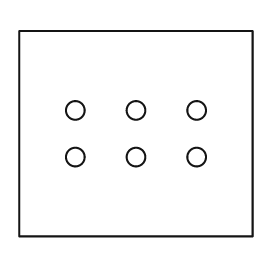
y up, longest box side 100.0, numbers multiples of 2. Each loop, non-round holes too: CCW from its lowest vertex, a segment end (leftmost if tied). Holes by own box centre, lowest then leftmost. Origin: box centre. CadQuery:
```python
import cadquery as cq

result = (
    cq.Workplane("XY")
    .moveTo(-50.0, -44.0)
    .lineTo(50.0, -44.0)
    .lineTo(50.0, 44.0)
    .lineTo(-50.0, 44.0)
    .close()
    .moveTo(-26.0, -10.0)
    .circle(4.0)
    .moveTo(0.0, -10.0)
    .circle(4.0)
    .moveTo(26.0, -10.0)
    .circle(4.0)
    .moveTo(-26.0, 10.0)
    .circle(4.0)
    .moveTo(0.0, 10.0)
    .circle(4.0)
    .moveTo(26.0, 10.0)
    .circle(4.0)
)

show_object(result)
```